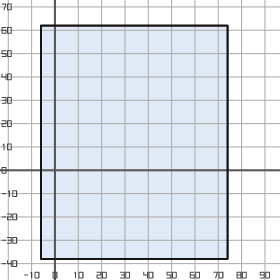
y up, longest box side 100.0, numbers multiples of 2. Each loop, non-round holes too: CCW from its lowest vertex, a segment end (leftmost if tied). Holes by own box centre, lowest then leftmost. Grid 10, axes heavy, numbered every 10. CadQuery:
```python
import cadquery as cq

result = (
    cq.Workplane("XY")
    .moveTo(-6.0, -38.0)
    .lineTo(74.0, -38.0)
    .lineTo(74.0, 62.0)
    .lineTo(-6.0, 62.0)
    .close()
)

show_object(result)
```